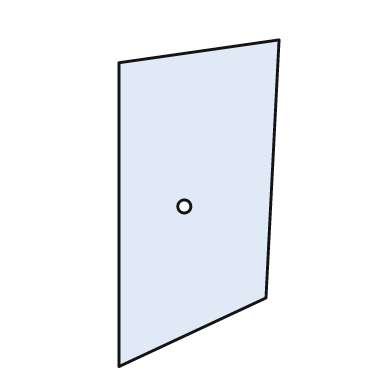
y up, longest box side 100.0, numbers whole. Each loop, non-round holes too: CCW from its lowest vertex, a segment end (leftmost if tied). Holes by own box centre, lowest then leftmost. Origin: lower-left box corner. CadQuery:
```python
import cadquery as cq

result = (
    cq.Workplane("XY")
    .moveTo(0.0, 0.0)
    .lineTo(45.0, 21.0)
    .lineTo(49.0, 100.0)
    .lineTo(0.0, 93.0)
    .close()
    .moveTo(20.0, 49.0)
    .circle(2.0)
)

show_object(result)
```